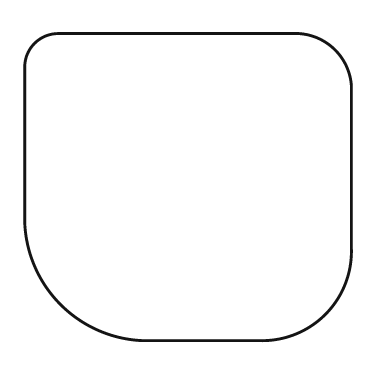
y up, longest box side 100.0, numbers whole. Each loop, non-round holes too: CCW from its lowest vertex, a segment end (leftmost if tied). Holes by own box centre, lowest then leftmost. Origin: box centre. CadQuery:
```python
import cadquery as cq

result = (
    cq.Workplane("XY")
    .moveTo(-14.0, -47.0)
    .lineTo(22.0, -47.0)
    .threePointArc((42.0, -39.0), (50.0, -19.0))
    .lineTo(50.0, 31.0)
    .threePointArc((45.0, 42.0), (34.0, 47.0))
    .lineTo(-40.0, 47.0)
    .threePointArc((-47.0, 44.0), (-50.0, 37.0))
    .lineTo(-50.0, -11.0)
    .threePointArc((-39.0, -36.0), (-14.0, -47.0))
    .close()
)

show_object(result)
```